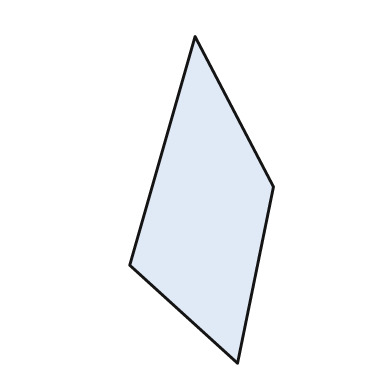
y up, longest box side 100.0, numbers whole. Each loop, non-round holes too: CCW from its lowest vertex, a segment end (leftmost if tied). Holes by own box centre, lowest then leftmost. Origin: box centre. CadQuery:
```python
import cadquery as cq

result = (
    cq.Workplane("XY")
    .moveTo(11.0, -50.0)
    .lineTo(22.0, 4.0)
    .lineTo(-2.0, 50.0)
    .lineTo(-22.0, -20.0)
    .close()
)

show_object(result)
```